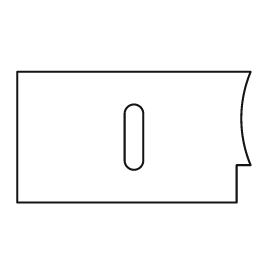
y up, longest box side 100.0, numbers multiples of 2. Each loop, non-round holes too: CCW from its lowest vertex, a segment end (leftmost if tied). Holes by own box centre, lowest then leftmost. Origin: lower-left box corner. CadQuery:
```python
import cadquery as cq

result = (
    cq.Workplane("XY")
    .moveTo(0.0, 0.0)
    .lineTo(94.0, 0.0)
    .lineTo(94.0, 16.0)
    .lineTo(100.0, 16.0)
    .threePointArc((96.0, 36.0), (100.0, 56.0))
    .lineTo(0.0, 56.0)
    .close()
    .moveTo(46.0, 18.0)
    .threePointArc((50.0, 14.0), (54.0, 18.0))
    .lineTo(54.0, 38.0)
    .threePointArc((50.0, 42.0), (46.0, 38.0))
    .close()
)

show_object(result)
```